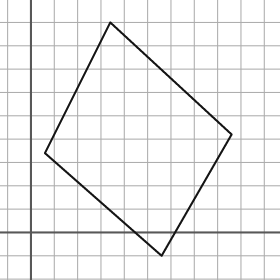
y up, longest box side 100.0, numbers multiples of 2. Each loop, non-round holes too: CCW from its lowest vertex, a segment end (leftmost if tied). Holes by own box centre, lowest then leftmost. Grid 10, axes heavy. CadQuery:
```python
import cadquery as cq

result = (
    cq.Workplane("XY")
    .moveTo(56.0, -10.0)
    .lineTo(86.0, 42.0)
    .lineTo(34.0, 90.0)
    .lineTo(6.0, 34.0)
    .close()
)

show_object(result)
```